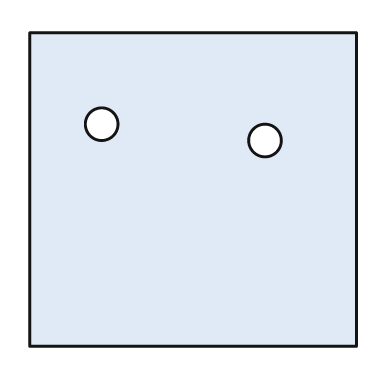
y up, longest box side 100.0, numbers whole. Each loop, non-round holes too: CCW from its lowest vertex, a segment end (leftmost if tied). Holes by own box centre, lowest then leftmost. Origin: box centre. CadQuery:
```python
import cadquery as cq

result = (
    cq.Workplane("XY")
    .moveTo(-50.0, -48.0)
    .lineTo(50.0, -48.0)
    .lineTo(50.0, 48.0)
    .lineTo(-50.0, 48.0)
    .close()
    .moveTo(22.0, 15.0)
    .circle(5.0)
    .moveTo(-28.0, 20.0)
    .circle(5.0)
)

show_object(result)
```